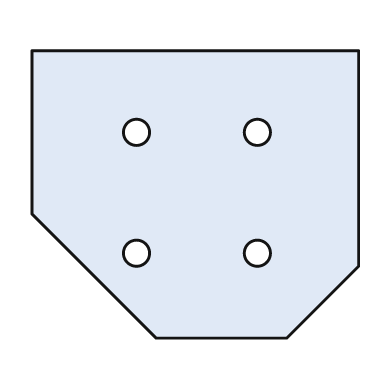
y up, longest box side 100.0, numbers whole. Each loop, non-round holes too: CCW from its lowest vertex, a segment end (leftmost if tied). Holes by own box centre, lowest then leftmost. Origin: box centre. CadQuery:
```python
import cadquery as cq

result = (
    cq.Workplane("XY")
    .moveTo(-12.0, -44.0)
    .lineTo(28.0, -44.0)
    .lineTo(50.0, -22.0)
    .lineTo(50.0, 44.0)
    .lineTo(-50.0, 44.0)
    .lineTo(-50.0, -6.0)
    .close()
    .moveTo(-18.0, -18.0)
    .circle(4.0)
    .moveTo(19.0, -18.0)
    .circle(4.0)
    .moveTo(-18.0, 19.0)
    .circle(4.0)
    .moveTo(19.0, 19.0)
    .circle(4.0)
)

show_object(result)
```